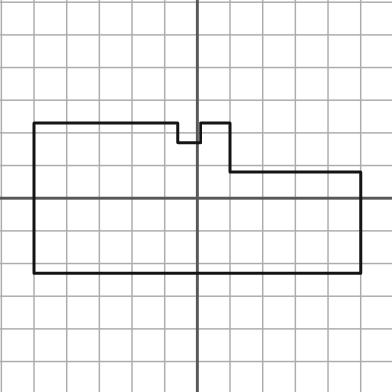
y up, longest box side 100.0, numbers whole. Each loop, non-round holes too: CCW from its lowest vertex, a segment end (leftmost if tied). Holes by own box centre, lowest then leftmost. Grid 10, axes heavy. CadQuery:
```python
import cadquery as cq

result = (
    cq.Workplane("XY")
    .moveTo(-50.0, -23.0)
    .lineTo(50.0, -23.0)
    .lineTo(50.0, 8.0)
    .lineTo(10.0, 8.0)
    .lineTo(10.0, 23.0)
    .lineTo(1.0, 23.0)
    .lineTo(1.0, 17.0)
    .lineTo(-6.0, 17.0)
    .lineTo(-6.0, 23.0)
    .lineTo(-50.0, 23.0)
    .close()
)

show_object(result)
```